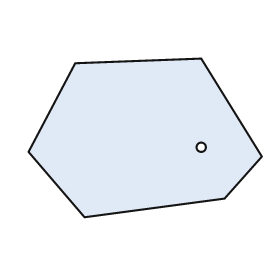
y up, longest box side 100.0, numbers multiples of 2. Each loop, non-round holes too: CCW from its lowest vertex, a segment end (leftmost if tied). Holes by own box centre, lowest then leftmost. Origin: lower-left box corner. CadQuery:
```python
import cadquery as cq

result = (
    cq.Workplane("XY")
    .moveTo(24.0, 0.0)
    .lineTo(84.0, 8.0)
    .lineTo(100.0, 26.0)
    .lineTo(74.0, 68.0)
    .lineTo(20.0, 66.0)
    .lineTo(0.0, 28.0)
    .close()
    .moveTo(74.0, 30.0)
    .circle(2.0)
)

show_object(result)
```